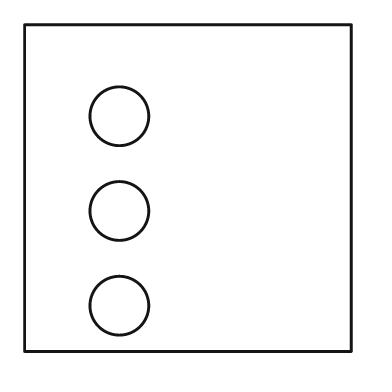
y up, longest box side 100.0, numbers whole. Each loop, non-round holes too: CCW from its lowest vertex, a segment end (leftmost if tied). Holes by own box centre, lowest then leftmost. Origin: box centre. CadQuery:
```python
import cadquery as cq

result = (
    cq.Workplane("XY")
    .moveTo(-50.0, -50.0)
    .lineTo(50.0, -50.0)
    .lineTo(50.0, 50.0)
    .lineTo(-50.0, 50.0)
    .close()
    .moveTo(-21.0, -36.0)
    .circle(9.0)
    .moveTo(-21.0, -7.0)
    .circle(9.0)
    .moveTo(-21.0, 22.0)
    .circle(9.0)
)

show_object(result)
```